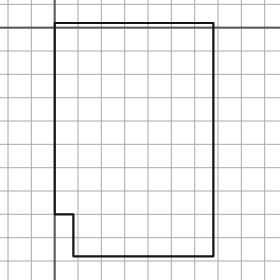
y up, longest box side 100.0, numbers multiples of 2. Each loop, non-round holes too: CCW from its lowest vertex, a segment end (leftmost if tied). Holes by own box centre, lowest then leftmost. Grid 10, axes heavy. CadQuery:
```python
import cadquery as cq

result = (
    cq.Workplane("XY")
    .moveTo(8.0, -98.0)
    .lineTo(68.0, -98.0)
    .lineTo(68.0, 2.0)
    .lineTo(0.0, 2.0)
    .lineTo(0.0, -80.0)
    .lineTo(8.0, -80.0)
    .close()
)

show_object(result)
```